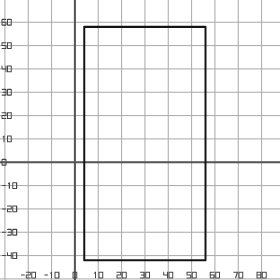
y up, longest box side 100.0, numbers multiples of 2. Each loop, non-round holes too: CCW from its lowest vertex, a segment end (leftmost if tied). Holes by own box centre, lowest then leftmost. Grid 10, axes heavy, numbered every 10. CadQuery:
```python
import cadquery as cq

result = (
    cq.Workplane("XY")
    .moveTo(4.0, -42.0)
    .lineTo(56.0, -42.0)
    .lineTo(56.0, 58.0)
    .lineTo(4.0, 58.0)
    .close()
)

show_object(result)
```